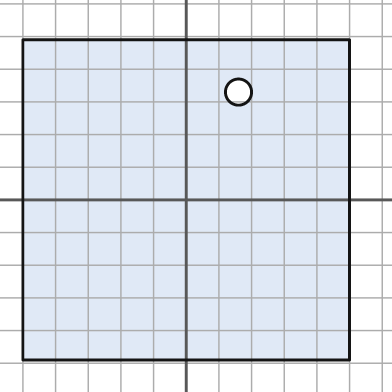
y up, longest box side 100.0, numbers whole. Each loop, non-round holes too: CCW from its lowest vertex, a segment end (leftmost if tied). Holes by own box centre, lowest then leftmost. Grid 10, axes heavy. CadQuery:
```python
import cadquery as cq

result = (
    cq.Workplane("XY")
    .moveTo(-50.0, -49.0)
    .lineTo(50.0, -49.0)
    .lineTo(50.0, 49.0)
    .lineTo(-50.0, 49.0)
    .close()
    .moveTo(16.0, 33.0)
    .circle(4.0)
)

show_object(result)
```